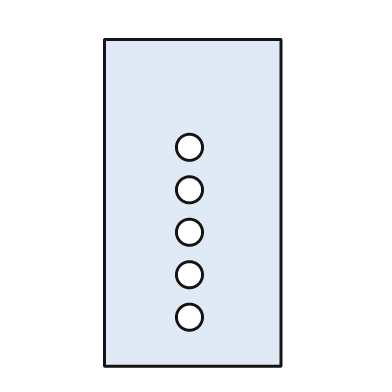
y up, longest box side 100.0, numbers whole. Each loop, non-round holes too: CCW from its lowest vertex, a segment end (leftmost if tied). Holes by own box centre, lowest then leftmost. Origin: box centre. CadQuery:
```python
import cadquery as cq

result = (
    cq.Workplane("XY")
    .moveTo(-27.0, -50.0)
    .lineTo(27.0, -50.0)
    .lineTo(27.0, 50.0)
    .lineTo(-27.0, 50.0)
    .close()
    .moveTo(-1.0, -35.0)
    .circle(4.0)
    .moveTo(-1.0, -22.0)
    .circle(4.0)
    .moveTo(-1.0, -9.0)
    .circle(4.0)
    .moveTo(-1.0, 4.0)
    .circle(4.0)
    .moveTo(-1.0, 17.0)
    .circle(4.0)
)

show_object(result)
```